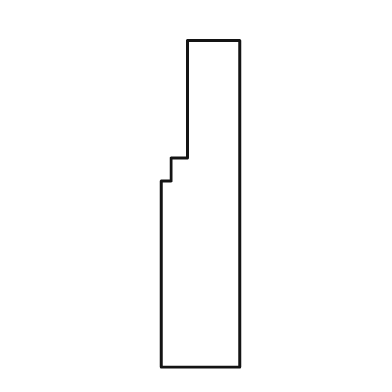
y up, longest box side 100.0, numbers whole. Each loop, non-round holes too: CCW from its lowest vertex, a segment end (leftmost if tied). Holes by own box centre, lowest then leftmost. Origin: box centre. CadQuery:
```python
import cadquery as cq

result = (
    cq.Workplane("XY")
    .moveTo(-12.0, -50.0)
    .lineTo(12.0, -50.0)
    .lineTo(12.0, 50.0)
    .lineTo(-4.0, 50.0)
    .lineTo(-4.0, 14.0)
    .lineTo(-9.0, 14.0)
    .lineTo(-9.0, 7.0)
    .lineTo(-12.0, 7.0)
    .close()
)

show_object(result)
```